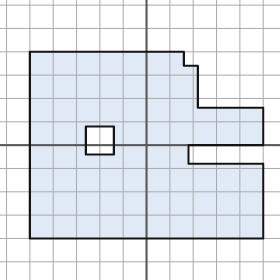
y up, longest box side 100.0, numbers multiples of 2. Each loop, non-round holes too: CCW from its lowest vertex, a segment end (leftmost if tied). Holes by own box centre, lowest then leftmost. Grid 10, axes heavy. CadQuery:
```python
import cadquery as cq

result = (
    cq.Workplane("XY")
    .moveTo(-50.0, -40.0)
    .lineTo(50.0, -40.0)
    .lineTo(50.0, -8.0)
    .lineTo(18.0, -8.0)
    .lineTo(18.0, 0.0)
    .lineTo(50.0, 0.0)
    .lineTo(50.0, 16.0)
    .lineTo(22.0, 16.0)
    .lineTo(22.0, 34.0)
    .lineTo(16.0, 34.0)
    .lineTo(16.0, 40.0)
    .lineTo(-50.0, 40.0)
    .close()
    .moveTo(-26.0, -4.0)
    .lineTo(-14.0, -4.0)
    .lineTo(-14.0, 8.0)
    .lineTo(-26.0, 8.0)
    .close()
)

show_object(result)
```